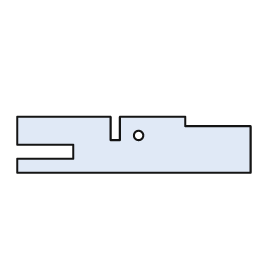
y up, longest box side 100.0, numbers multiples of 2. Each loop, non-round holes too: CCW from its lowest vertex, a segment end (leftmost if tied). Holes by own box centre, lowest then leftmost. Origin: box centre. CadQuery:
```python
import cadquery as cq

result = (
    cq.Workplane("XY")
    .moveTo(-50.0, -12.0)
    .lineTo(50.0, -12.0)
    .lineTo(50.0, 8.0)
    .lineTo(22.0, 8.0)
    .lineTo(22.0, 12.0)
    .lineTo(-6.0, 12.0)
    .lineTo(-6.0, 2.0)
    .lineTo(-10.0, 2.0)
    .lineTo(-10.0, 12.0)
    .lineTo(-50.0, 12.0)
    .lineTo(-50.0, 0.0)
    .lineTo(-26.0, 0.0)
    .lineTo(-26.0, -6.0)
    .lineTo(-50.0, -6.0)
    .close()
    .moveTo(2.0, 4.0)
    .circle(2.0)
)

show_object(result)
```